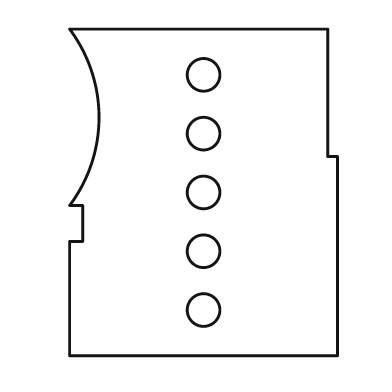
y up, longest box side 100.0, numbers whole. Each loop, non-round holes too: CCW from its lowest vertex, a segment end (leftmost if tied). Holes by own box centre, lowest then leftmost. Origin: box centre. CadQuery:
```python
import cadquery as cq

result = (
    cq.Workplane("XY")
    .moveTo(-41.0, -50.0)
    .lineTo(41.0, -50.0)
    .lineTo(41.0, 11.0)
    .lineTo(38.0, 11.0)
    .lineTo(38.0, 50.0)
    .lineTo(-41.0, 50.0)
    .threePointArc((-32.0, 23.0), (-41.0, -4.0))
    .lineTo(-37.0, -4.0)
    .lineTo(-37.0, -15.0)
    .lineTo(-41.0, -15.0)
    .close()
    .moveTo(0.0, -36.0)
    .circle(5.0)
    .moveTo(0.0, -18.0)
    .circle(5.0)
    .moveTo(0.0, 0.0)
    .circle(5.0)
    .moveTo(0.0, 18.0)
    .circle(5.0)
    .moveTo(0.0, 36.0)
    .circle(5.0)
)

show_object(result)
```